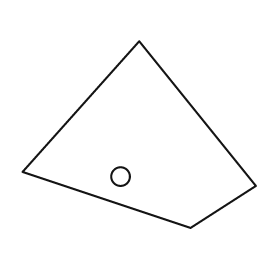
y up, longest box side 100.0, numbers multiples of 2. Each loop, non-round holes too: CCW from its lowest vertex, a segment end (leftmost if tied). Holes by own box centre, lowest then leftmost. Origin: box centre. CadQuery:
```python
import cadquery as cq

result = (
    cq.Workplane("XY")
    .moveTo(22.0, -40.0)
    .lineTo(50.0, -22.0)
    .lineTo(0.0, 40.0)
    .lineTo(-50.0, -16.0)
    .close()
    .moveTo(-8.0, -18.0)
    .circle(4.0)
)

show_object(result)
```